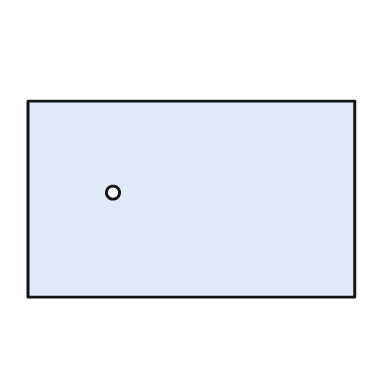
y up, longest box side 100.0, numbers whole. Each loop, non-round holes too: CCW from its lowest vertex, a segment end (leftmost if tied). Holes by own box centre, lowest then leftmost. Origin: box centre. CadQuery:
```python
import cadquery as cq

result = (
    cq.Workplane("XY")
    .moveTo(-50.0, -30.0)
    .lineTo(50.0, -30.0)
    .lineTo(50.0, 30.0)
    .lineTo(-50.0, 30.0)
    .close()
    .moveTo(-24.0, 2.0)
    .circle(2.0)
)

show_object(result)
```